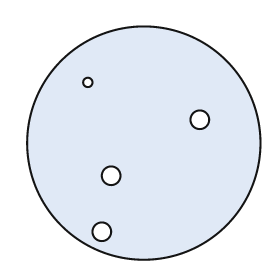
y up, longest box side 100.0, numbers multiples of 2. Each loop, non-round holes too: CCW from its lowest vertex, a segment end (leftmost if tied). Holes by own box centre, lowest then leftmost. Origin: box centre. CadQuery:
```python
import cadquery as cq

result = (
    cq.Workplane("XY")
    .moveTo(0.0, 0.0)
    .circle(50.0)
    .moveTo(-18.0, -38.0)
    .circle(4.0)
    .moveTo(-14.0, -14.0)
    .circle(4.0)
    .moveTo(24.0, 10.0)
    .circle(4.0)
    .moveTo(-24.0, 26.0)
    .circle(2.0)
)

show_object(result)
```